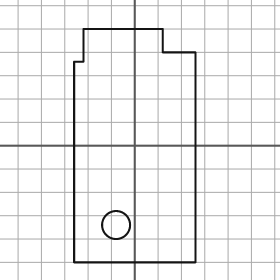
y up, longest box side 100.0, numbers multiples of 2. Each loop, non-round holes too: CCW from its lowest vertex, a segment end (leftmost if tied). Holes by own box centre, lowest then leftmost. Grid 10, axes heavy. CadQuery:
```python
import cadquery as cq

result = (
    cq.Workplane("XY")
    .moveTo(-26.0, -50.0)
    .lineTo(26.0, -50.0)
    .lineTo(26.0, 40.0)
    .lineTo(12.0, 40.0)
    .lineTo(12.0, 50.0)
    .lineTo(-22.0, 50.0)
    .lineTo(-22.0, 36.0)
    .lineTo(-26.0, 36.0)
    .close()
    .moveTo(-8.0, -34.0)
    .circle(6.0)
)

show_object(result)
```